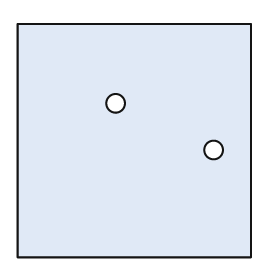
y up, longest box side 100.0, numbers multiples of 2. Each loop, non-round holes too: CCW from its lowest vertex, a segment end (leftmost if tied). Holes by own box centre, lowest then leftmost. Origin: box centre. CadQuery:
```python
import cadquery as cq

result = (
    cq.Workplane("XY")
    .moveTo(-50.0, -50.0)
    .lineTo(50.0, -50.0)
    .lineTo(50.0, 50.0)
    .lineTo(-50.0, 50.0)
    .close()
    .moveTo(34.0, -4.0)
    .circle(4.0)
    .moveTo(-8.0, 16.0)
    .circle(4.0)
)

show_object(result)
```